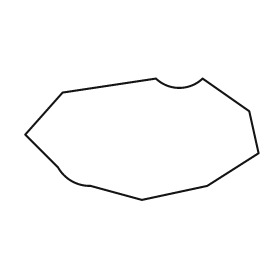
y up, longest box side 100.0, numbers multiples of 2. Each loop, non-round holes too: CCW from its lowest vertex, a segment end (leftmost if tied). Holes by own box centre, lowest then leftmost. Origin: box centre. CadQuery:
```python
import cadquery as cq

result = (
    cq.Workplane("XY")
    .moveTo(0.0, -26.0)
    .lineTo(28.0, -20.0)
    .lineTo(50.0, -6.0)
    .lineTo(46.0, 12.0)
    .lineTo(26.0, 26.0)
    .threePointArc((16.0, 22.0), (6.0, 26.0))
    .lineTo(-34.0, 20.0)
    .lineTo(-50.0, 2.0)
    .lineTo(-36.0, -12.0)
    .threePointArc((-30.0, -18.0), (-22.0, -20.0))
    .close()
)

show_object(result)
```